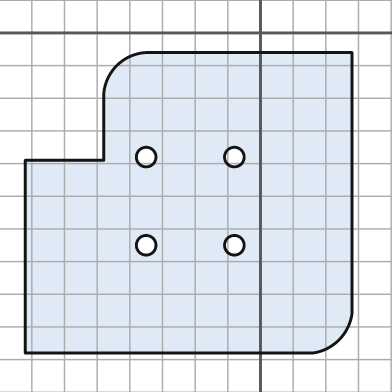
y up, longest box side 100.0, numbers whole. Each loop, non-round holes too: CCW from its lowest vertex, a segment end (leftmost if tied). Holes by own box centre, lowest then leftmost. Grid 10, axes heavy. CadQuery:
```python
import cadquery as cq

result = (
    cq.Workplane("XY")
    .moveTo(-72.0, -98.0)
    .lineTo(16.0, -98.0)
    .threePointArc((24.0, -94.0), (28.0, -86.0))
    .lineTo(28.0, -6.0)
    .lineTo(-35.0, -6.0)
    .threePointArc((-44.0, -10.0), (-48.0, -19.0))
    .lineTo(-48.0, -39.0)
    .lineTo(-72.0, -39.0)
    .close()
    .moveTo(-35.0, -65.0)
    .circle(3.0)
    .moveTo(-8.0, -65.0)
    .circle(3.0)
    .moveTo(-35.0, -38.0)
    .circle(3.0)
    .moveTo(-8.0, -38.0)
    .circle(3.0)
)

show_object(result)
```